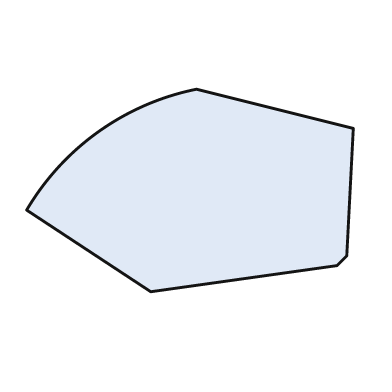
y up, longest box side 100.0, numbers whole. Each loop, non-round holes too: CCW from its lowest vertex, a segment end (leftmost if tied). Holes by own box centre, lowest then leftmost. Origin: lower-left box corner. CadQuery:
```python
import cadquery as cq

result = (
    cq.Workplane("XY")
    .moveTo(38.0, 0.0)
    .lineTo(95.0, 8.0)
    .lineTo(98.0, 11.0)
    .lineTo(100.0, 50.0)
    .lineTo(52.0, 62.0)
    .threePointArc((22.0, 49.0), (0.0, 25.0))
    .close()
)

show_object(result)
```